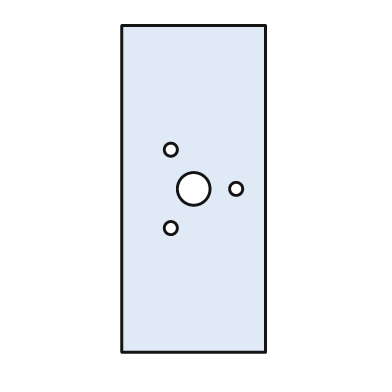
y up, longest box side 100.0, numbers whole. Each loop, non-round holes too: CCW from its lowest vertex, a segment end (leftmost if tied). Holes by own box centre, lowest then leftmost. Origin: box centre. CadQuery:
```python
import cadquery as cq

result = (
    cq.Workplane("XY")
    .moveTo(-22.0, -50.0)
    .lineTo(22.0, -50.0)
    .lineTo(22.0, 50.0)
    .lineTo(-22.0, 50.0)
    .close()
    .moveTo(-7.0, -12.0)
    .circle(2.0)
    .moveTo(0.0, 0.0)
    .circle(5.0)
    .moveTo(13.0, 0.0)
    .circle(2.0)
    .moveTo(-7.0, 12.0)
    .circle(2.0)
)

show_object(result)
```